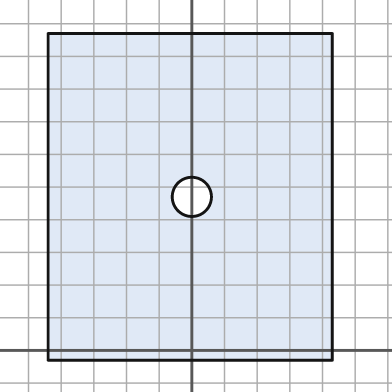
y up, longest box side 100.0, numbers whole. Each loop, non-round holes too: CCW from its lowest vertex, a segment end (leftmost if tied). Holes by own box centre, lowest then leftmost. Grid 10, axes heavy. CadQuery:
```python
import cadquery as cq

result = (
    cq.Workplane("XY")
    .moveTo(-44.0, -3.0)
    .lineTo(43.0, -3.0)
    .lineTo(43.0, 97.0)
    .lineTo(-44.0, 97.0)
    .close()
    .moveTo(0.0, 47.0)
    .circle(6.0)
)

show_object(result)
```